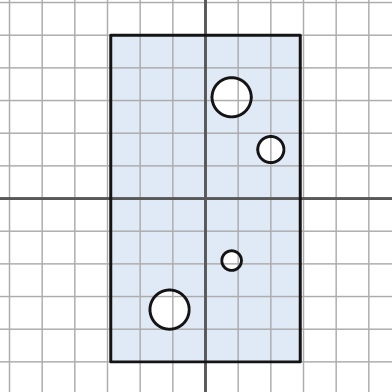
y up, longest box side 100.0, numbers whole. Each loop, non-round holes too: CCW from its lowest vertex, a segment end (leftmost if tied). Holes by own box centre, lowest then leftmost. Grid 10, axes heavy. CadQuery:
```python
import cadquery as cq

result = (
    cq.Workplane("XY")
    .moveTo(-29.0, -50.0)
    .lineTo(29.0, -50.0)
    .lineTo(29.0, 50.0)
    .lineTo(-29.0, 50.0)
    .close()
    .moveTo(-11.0, -34.0)
    .circle(6.0)
    .moveTo(8.0, -19.0)
    .circle(3.0)
    .moveTo(20.0, 15.0)
    .circle(4.0)
    .moveTo(8.0, 31.0)
    .circle(6.0)
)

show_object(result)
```